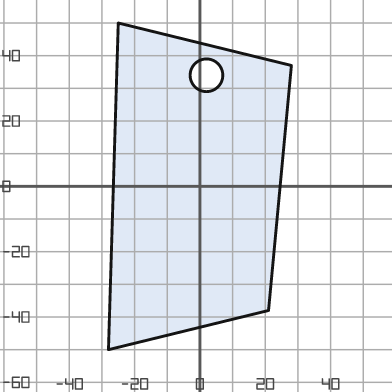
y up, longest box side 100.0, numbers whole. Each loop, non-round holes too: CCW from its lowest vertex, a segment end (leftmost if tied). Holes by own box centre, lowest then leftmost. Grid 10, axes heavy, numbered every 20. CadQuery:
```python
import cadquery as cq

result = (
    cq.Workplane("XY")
    .moveTo(-28.0, -50.0)
    .lineTo(21.0, -38.0)
    .lineTo(28.0, 37.0)
    .lineTo(-25.0, 50.0)
    .close()
    .moveTo(2.0, 34.0)
    .circle(5.0)
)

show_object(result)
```